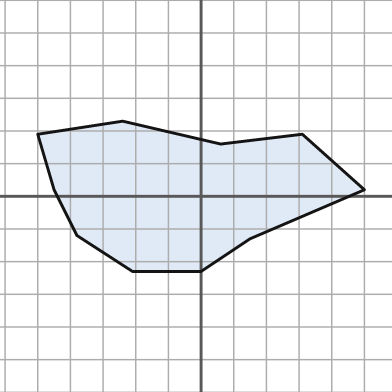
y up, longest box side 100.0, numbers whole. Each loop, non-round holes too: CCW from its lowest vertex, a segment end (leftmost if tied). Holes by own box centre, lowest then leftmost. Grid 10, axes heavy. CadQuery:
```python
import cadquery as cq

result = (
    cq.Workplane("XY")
    .moveTo(-21.0, -23.0)
    .lineTo(0.0, -23.0)
    .lineTo(15.0, -13.0)
    .lineTo(50.0, 2.0)
    .lineTo(31.0, 19.0)
    .lineTo(6.0, 16.0)
    .lineTo(-24.0, 23.0)
    .lineTo(-50.0, 19.0)
    .lineTo(-45.0, 2.0)
    .lineTo(-38.0, -12.0)
    .close()
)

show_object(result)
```